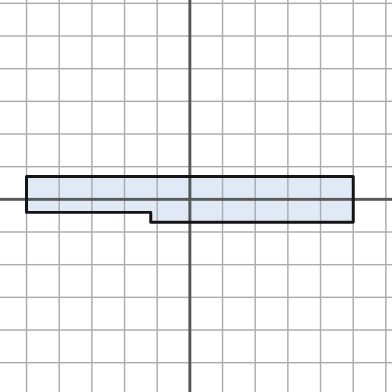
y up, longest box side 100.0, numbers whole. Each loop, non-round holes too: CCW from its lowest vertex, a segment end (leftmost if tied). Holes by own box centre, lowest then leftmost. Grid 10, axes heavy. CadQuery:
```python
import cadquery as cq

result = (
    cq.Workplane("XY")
    .moveTo(-12.0, -7.0)
    .lineTo(50.0, -7.0)
    .lineTo(50.0, 7.0)
    .lineTo(-50.0, 7.0)
    .lineTo(-50.0, -4.0)
    .lineTo(-12.0, -4.0)
    .close()
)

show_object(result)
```